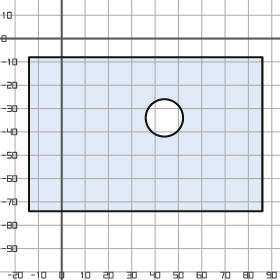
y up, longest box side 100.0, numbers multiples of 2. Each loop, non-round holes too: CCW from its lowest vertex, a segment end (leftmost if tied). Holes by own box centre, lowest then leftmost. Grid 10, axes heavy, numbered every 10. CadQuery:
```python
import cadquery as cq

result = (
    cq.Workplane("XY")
    .moveTo(-14.0, -74.0)
    .lineTo(86.0, -74.0)
    .lineTo(86.0, -8.0)
    .lineTo(-14.0, -8.0)
    .close()
    .moveTo(44.0, -34.0)
    .circle(8.0)
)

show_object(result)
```